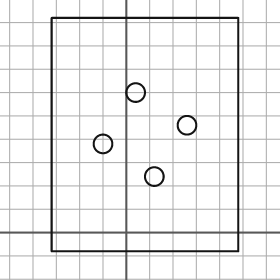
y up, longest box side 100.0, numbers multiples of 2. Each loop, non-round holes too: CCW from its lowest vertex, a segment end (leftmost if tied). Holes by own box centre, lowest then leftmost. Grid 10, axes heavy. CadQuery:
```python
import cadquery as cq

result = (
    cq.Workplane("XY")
    .moveTo(-32.0, -8.0)
    .lineTo(48.0, -8.0)
    .lineTo(48.0, 92.0)
    .lineTo(-32.0, 92.0)
    .close()
    .moveTo(12.0, 24.0)
    .circle(4.0)
    .moveTo(-10.0, 38.0)
    .circle(4.0)
    .moveTo(26.0, 46.0)
    .circle(4.0)
    .moveTo(4.0, 60.0)
    .circle(4.0)
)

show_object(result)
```